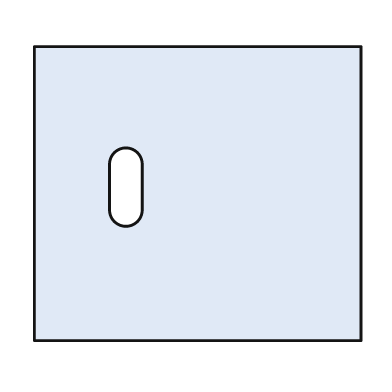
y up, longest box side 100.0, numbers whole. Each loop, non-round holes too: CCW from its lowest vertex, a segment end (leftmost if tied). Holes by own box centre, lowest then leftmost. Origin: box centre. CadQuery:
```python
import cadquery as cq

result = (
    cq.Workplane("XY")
    .moveTo(-50.0, -45.0)
    .lineTo(50.0, -45.0)
    .lineTo(50.0, 45.0)
    .lineTo(-50.0, 45.0)
    .close()
    .moveTo(-27.0, -5.0)
    .threePointArc((-22.0, -10.0), (-17.0, -5.0))
    .lineTo(-17.0, 9.0)
    .threePointArc((-22.0, 14.0), (-27.0, 9.0))
    .close()
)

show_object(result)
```